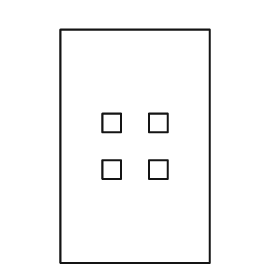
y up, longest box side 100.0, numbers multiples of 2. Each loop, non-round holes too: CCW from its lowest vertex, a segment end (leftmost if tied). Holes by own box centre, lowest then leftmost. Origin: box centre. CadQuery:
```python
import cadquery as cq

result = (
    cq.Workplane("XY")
    .moveTo(-32.0, -50.0)
    .lineTo(32.0, -50.0)
    .lineTo(32.0, 50.0)
    .lineTo(-32.0, 50.0)
    .close()
    .moveTo(-14.0, -14.0)
    .lineTo(-6.0, -14.0)
    .lineTo(-6.0, -6.0)
    .lineTo(-14.0, -6.0)
    .close()
    .moveTo(6.0, -14.0)
    .lineTo(14.0, -14.0)
    .lineTo(14.0, -6.0)
    .lineTo(6.0, -6.0)
    .close()
    .moveTo(-14.0, 6.0)
    .lineTo(-6.0, 6.0)
    .lineTo(-6.0, 14.0)
    .lineTo(-14.0, 14.0)
    .close()
    .moveTo(6.0, 6.0)
    .lineTo(14.0, 6.0)
    .lineTo(14.0, 14.0)
    .lineTo(6.0, 14.0)
    .close()
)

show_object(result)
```